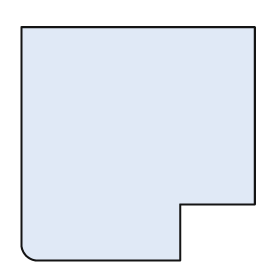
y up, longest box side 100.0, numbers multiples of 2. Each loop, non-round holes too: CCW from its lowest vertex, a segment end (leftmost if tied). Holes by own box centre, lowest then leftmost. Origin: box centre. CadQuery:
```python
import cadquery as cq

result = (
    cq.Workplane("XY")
    .moveTo(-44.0, -50.0)
    .lineTo(18.0, -50.0)
    .lineTo(18.0, -26.0)
    .lineTo(50.0, -26.0)
    .lineTo(50.0, 50.0)
    .lineTo(-50.0, 50.0)
    .lineTo(-50.0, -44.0)
    .threePointArc((-48.0, -48.0), (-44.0, -50.0))
    .close()
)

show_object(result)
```